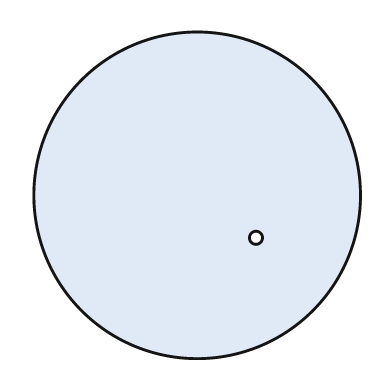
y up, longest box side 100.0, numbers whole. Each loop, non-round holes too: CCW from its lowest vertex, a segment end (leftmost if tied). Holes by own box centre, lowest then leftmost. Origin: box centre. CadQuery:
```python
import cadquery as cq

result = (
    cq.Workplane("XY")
    .moveTo(0.0, 0.0)
    .circle(50.0)
    .moveTo(18.0, -13.0)
    .circle(2.0)
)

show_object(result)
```